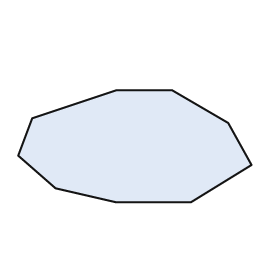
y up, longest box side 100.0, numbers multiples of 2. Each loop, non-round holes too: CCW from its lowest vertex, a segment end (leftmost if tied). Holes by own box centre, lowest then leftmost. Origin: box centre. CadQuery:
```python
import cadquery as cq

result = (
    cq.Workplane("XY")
    .moveTo(-8.0, -24.0)
    .lineTo(24.0, -24.0)
    .lineTo(50.0, -8.0)
    .lineTo(40.0, 10.0)
    .lineTo(16.0, 24.0)
    .lineTo(-8.0, 24.0)
    .lineTo(-44.0, 12.0)
    .lineTo(-50.0, -4.0)
    .lineTo(-34.0, -18.0)
    .close()
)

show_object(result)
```